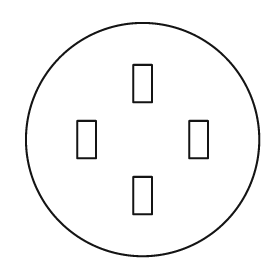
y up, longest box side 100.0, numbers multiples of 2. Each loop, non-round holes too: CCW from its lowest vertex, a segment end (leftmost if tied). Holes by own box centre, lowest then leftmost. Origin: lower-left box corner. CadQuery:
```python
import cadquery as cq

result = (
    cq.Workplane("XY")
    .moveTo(50.0, 50.0)
    .circle(50.0)
    .moveTo(46.0, 18.0)
    .lineTo(54.0, 18.0)
    .lineTo(54.0, 34.0)
    .lineTo(46.0, 34.0)
    .close()
    .moveTo(22.0, 42.0)
    .lineTo(30.0, 42.0)
    .lineTo(30.0, 58.0)
    .lineTo(22.0, 58.0)
    .close()
    .moveTo(70.0, 42.0)
    .lineTo(78.0, 42.0)
    .lineTo(78.0, 58.0)
    .lineTo(70.0, 58.0)
    .close()
    .moveTo(46.0, 66.0)
    .lineTo(54.0, 66.0)
    .lineTo(54.0, 82.0)
    .lineTo(46.0, 82.0)
    .close()
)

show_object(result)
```